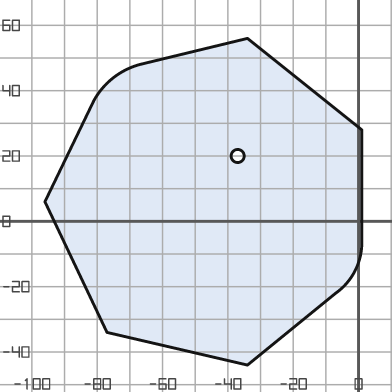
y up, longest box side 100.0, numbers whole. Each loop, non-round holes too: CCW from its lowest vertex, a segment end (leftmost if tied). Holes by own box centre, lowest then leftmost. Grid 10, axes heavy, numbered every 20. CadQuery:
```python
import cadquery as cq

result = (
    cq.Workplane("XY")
    .moveTo(-34.0, -44.0)
    .lineTo(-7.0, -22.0)
    .threePointArc((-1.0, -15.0), (1.0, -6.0))
    .lineTo(1.0, 28.0)
    .lineTo(-34.0, 56.0)
    .lineTo(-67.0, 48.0)
    .threePointArc((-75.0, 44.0), (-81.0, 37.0))
    .lineTo(-96.0, 6.0)
    .lineTo(-77.0, -34.0)
    .close()
    .moveTo(-37.0, 20.0)
    .circle(2.0)
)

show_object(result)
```